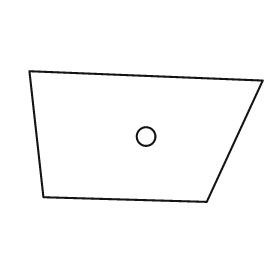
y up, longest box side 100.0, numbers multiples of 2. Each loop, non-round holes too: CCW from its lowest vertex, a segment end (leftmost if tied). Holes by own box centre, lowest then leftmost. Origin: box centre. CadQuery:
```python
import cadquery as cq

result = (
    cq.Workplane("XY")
    .moveTo(26.0, -28.0)
    .lineTo(50.0, 24.0)
    .lineTo(-50.0, 28.0)
    .lineTo(-44.0, -26.0)
    .close()
    .moveTo(0.0, 0.0)
    .circle(4.0)
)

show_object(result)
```